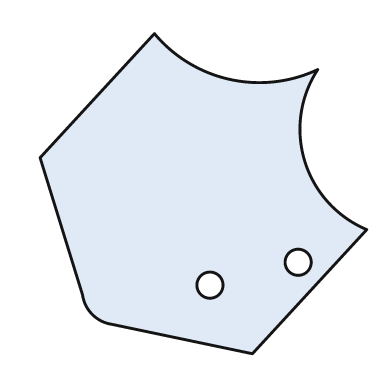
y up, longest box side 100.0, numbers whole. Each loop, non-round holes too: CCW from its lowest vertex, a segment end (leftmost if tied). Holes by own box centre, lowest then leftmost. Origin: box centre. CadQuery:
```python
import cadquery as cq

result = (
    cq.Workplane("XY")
    .moveTo(15.0, -49.0)
    .lineTo(50.0, -11.0)
    .threePointArc((31.0, 10.0), (35.0, 38.0))
    .threePointArc((8.0, 35.0), (-15.0, 49.0))
    .lineTo(-50.0, 11.0)
    .lineTo(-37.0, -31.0)
    .threePointArc((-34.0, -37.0), (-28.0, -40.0))
    .close()
    .moveTo(2.0, -28.0)
    .circle(4.0)
    .moveTo(29.0, -21.0)
    .circle(4.0)
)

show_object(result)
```